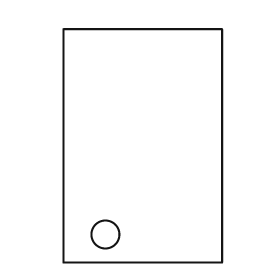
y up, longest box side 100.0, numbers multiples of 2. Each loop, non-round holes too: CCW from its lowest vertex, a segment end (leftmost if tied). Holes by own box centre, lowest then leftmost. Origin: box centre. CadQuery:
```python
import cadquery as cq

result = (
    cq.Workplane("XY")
    .moveTo(-34.0, -50.0)
    .lineTo(34.0, -50.0)
    .lineTo(34.0, 50.0)
    .lineTo(-34.0, 50.0)
    .close()
    .moveTo(-16.0, -38.0)
    .circle(6.0)
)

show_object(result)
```